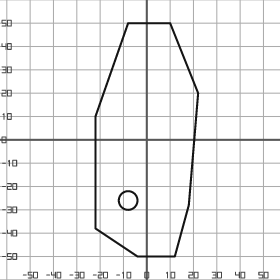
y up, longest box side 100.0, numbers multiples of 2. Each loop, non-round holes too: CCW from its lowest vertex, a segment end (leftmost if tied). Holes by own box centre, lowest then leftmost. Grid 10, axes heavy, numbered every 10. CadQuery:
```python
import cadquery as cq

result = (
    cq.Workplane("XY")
    .moveTo(-4.0, -50.0)
    .lineTo(12.0, -50.0)
    .lineTo(18.0, -28.0)
    .lineTo(22.0, 20.0)
    .lineTo(10.0, 50.0)
    .lineTo(-8.0, 50.0)
    .lineTo(-22.0, 10.0)
    .lineTo(-22.0, -38.0)
    .close()
    .moveTo(-8.0, -26.0)
    .circle(4.0)
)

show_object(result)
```